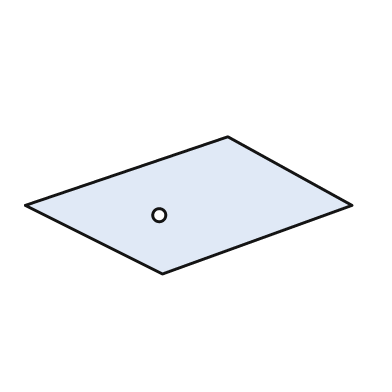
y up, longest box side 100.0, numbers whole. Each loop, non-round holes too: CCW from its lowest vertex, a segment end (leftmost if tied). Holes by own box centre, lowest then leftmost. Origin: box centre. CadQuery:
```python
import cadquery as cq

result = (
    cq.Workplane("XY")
    .moveTo(-8.0, -21.0)
    .lineTo(50.0, 0.0)
    .lineTo(12.0, 21.0)
    .lineTo(-50.0, 0.0)
    .close()
    .moveTo(-9.0, -3.0)
    .circle(2.0)
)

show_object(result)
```